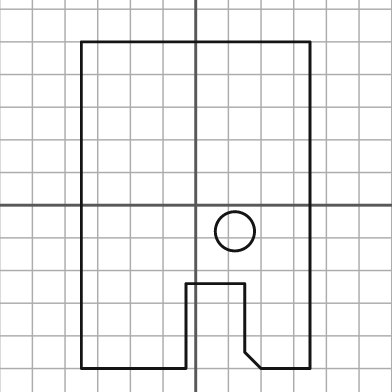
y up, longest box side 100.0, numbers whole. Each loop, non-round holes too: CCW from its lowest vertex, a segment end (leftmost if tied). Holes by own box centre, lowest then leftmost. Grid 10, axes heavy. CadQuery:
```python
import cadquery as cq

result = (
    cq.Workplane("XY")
    .moveTo(-35.0, -50.0)
    .lineTo(-3.0, -50.0)
    .lineTo(-3.0, -24.0)
    .lineTo(15.0, -24.0)
    .lineTo(15.0, -45.0)
    .lineTo(20.0, -50.0)
    .lineTo(35.0, -50.0)
    .lineTo(35.0, 50.0)
    .lineTo(-35.0, 50.0)
    .close()
    .moveTo(12.0, -8.0)
    .circle(6.0)
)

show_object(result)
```